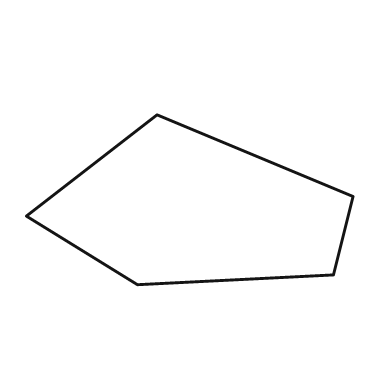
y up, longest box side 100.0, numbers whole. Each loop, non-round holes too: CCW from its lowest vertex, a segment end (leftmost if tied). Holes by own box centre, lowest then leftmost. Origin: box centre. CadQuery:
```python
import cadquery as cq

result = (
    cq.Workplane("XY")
    .moveTo(-16.0, -26.0)
    .lineTo(44.0, -23.0)
    .lineTo(50.0, 1.0)
    .lineTo(-10.0, 26.0)
    .lineTo(-50.0, -5.0)
    .close()
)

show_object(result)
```